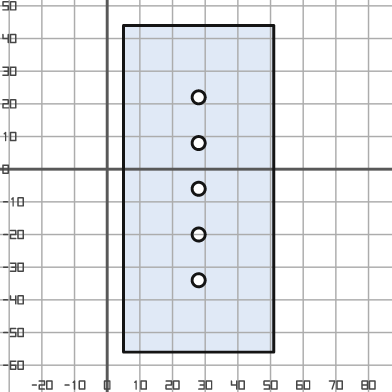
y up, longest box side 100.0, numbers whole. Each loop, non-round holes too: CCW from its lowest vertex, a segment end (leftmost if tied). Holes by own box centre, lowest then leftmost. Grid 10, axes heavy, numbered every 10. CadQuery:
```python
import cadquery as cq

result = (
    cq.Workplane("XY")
    .moveTo(5.0, -56.0)
    .lineTo(51.0, -56.0)
    .lineTo(51.0, 44.0)
    .lineTo(5.0, 44.0)
    .close()
    .moveTo(28.0, -34.0)
    .circle(2.0)
    .moveTo(28.0, -20.0)
    .circle(2.0)
    .moveTo(28.0, -6.0)
    .circle(2.0)
    .moveTo(28.0, 8.0)
    .circle(2.0)
    .moveTo(28.0, 22.0)
    .circle(2.0)
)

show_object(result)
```